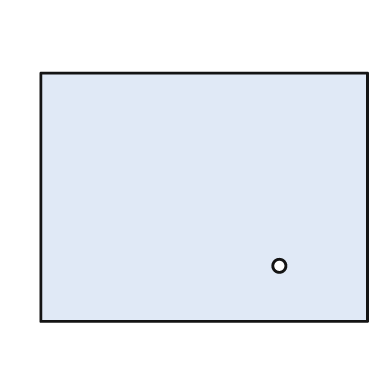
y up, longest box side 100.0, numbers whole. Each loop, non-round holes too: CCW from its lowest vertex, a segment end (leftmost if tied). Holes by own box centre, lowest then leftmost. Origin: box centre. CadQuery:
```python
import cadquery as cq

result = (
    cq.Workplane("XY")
    .moveTo(-50.0, -38.0)
    .lineTo(50.0, -38.0)
    .lineTo(50.0, 38.0)
    .lineTo(-50.0, 38.0)
    .close()
    .moveTo(23.0, -21.0)
    .circle(2.0)
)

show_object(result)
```